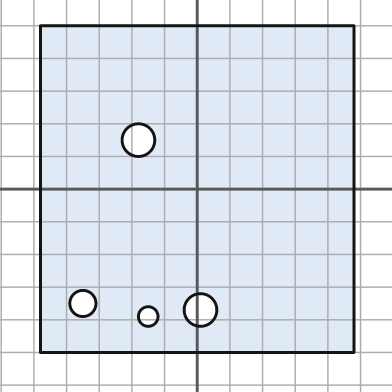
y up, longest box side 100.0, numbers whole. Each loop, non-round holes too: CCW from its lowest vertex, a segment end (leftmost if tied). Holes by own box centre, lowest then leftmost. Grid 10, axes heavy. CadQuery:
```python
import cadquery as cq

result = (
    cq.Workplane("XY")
    .moveTo(-48.0, -50.0)
    .lineTo(48.0, -50.0)
    .lineTo(48.0, 50.0)
    .lineTo(-48.0, 50.0)
    .close()
    .moveTo(-15.0, -39.0)
    .circle(3.0)
    .moveTo(1.0, -37.0)
    .circle(5.0)
    .moveTo(-35.0, -35.0)
    .circle(4.0)
    .moveTo(-18.0, 15.0)
    .circle(5.0)
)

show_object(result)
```